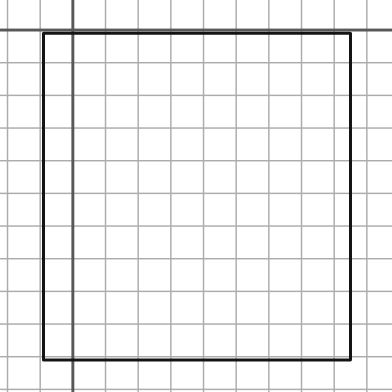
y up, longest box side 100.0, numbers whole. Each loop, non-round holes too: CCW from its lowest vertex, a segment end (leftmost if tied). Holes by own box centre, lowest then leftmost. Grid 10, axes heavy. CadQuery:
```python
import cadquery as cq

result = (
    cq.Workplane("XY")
    .moveTo(-9.0, -101.0)
    .lineTo(85.0, -101.0)
    .lineTo(85.0, -1.0)
    .lineTo(-9.0, -1.0)
    .close()
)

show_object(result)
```